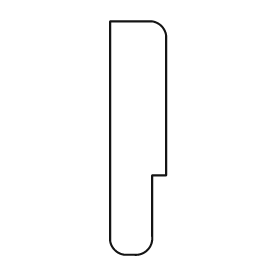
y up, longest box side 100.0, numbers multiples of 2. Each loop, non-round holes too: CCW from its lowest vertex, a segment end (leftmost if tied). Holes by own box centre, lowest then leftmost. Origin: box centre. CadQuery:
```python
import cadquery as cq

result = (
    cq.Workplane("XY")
    .moveTo(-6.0, -50.0)
    .lineTo(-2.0, -50.0)
    .threePointArc((4.0, -48.0), (6.0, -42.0))
    .lineTo(6.0, -16.0)
    .lineTo(12.0, -16.0)
    .lineTo(12.0, 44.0)
    .threePointArc((10.0, 48.0), (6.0, 50.0))
    .lineTo(-12.0, 50.0)
    .lineTo(-12.0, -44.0)
    .threePointArc((-10.0, -48.0), (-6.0, -50.0))
    .close()
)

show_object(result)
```